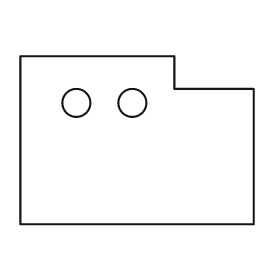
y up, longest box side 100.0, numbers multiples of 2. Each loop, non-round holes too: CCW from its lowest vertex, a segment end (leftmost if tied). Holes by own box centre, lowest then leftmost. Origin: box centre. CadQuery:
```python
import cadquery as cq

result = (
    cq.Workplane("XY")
    .moveTo(-50.0, -36.0)
    .lineTo(50.0, -36.0)
    .lineTo(50.0, 22.0)
    .lineTo(16.0, 22.0)
    .lineTo(16.0, 36.0)
    .lineTo(-50.0, 36.0)
    .close()
    .moveTo(-26.0, 16.0)
    .circle(6.0)
    .moveTo(-2.0, 16.0)
    .circle(6.0)
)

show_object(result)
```